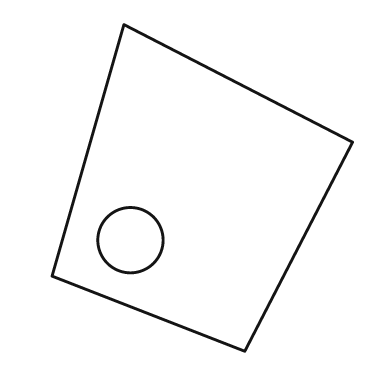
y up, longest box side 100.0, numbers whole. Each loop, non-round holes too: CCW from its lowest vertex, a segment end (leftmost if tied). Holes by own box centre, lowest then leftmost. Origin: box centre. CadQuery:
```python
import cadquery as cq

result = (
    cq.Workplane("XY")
    .moveTo(13.0, -50.0)
    .lineTo(46.0, 14.0)
    .lineTo(-24.0, 50.0)
    .lineTo(-46.0, -27.0)
    .close()
    .moveTo(-22.0, -16.0)
    .circle(10.0)
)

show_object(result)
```